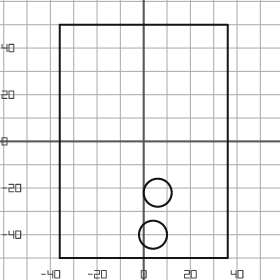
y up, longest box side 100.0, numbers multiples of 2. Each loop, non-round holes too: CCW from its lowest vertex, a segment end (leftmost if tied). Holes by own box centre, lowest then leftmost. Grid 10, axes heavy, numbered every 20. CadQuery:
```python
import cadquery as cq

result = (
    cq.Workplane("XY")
    .moveTo(-36.0, -50.0)
    .lineTo(36.0, -50.0)
    .lineTo(36.0, 50.0)
    .lineTo(-36.0, 50.0)
    .close()
    .moveTo(4.0, -40.0)
    .circle(6.0)
    .moveTo(6.0, -22.0)
    .circle(6.0)
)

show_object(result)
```